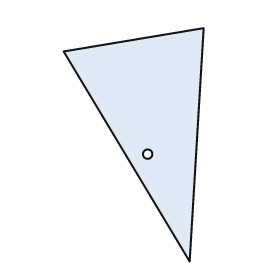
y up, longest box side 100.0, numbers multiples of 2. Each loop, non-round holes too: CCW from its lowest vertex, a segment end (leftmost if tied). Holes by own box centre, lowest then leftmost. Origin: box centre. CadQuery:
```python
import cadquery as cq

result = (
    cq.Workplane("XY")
    .moveTo(24.0, -50.0)
    .lineTo(30.0, 50.0)
    .lineTo(-30.0, 40.0)
    .close()
    .moveTo(6.0, -4.0)
    .circle(2.0)
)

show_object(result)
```